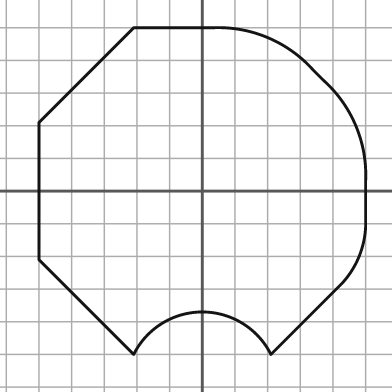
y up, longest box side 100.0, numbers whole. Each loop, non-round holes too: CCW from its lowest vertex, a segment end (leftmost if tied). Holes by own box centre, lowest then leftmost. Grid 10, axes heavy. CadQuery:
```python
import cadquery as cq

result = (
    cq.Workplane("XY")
    .moveTo(-21.0, -50.0)
    .threePointArc((0.0, -37.0), (21.0, -50.0))
    .lineTo(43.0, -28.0)
    .threePointArc((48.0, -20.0), (50.0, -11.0))
    .lineTo(50.0, 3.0)
    .threePointArc((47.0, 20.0), (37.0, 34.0))
    .lineTo(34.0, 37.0)
    .threePointArc((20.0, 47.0), (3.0, 50.0))
    .lineTo(-21.0, 50.0)
    .lineTo(-50.0, 21.0)
    .lineTo(-50.0, -21.0)
    .close()
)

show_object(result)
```